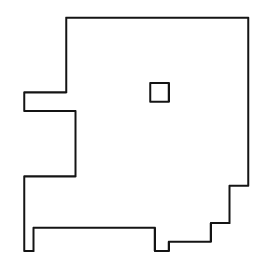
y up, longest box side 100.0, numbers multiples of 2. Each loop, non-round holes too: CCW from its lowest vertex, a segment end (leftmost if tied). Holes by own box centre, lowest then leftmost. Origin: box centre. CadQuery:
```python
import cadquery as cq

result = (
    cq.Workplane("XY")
    .moveTo(-48.0, -50.0)
    .lineTo(-44.0, -50.0)
    .lineTo(-44.0, -40.0)
    .lineTo(8.0, -40.0)
    .lineTo(8.0, -50.0)
    .lineTo(14.0, -50.0)
    .lineTo(14.0, -46.0)
    .lineTo(32.0, -46.0)
    .lineTo(32.0, -38.0)
    .lineTo(40.0, -38.0)
    .lineTo(40.0, -22.0)
    .lineTo(48.0, -22.0)
    .lineTo(48.0, 50.0)
    .lineTo(-30.0, 50.0)
    .lineTo(-30.0, 18.0)
    .lineTo(-48.0, 18.0)
    .lineTo(-48.0, 10.0)
    .lineTo(-26.0, 10.0)
    .lineTo(-26.0, -18.0)
    .lineTo(-48.0, -18.0)
    .close()
    .moveTo(6.0, 14.0)
    .lineTo(14.0, 14.0)
    .lineTo(14.0, 22.0)
    .lineTo(6.0, 22.0)
    .close()
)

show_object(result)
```